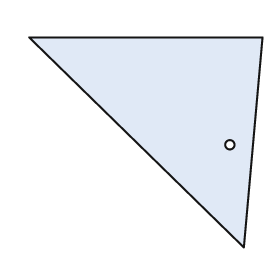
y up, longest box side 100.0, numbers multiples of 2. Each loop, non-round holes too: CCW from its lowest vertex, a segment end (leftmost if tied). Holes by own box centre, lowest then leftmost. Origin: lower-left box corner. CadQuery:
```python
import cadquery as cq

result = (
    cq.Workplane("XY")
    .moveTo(92.0, 0.0)
    .lineTo(100.0, 90.0)
    .lineTo(0.0, 90.0)
    .close()
    .moveTo(86.0, 44.0)
    .circle(2.0)
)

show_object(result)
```